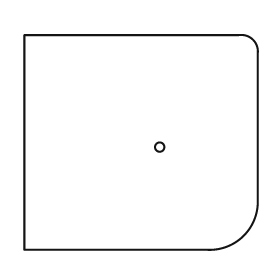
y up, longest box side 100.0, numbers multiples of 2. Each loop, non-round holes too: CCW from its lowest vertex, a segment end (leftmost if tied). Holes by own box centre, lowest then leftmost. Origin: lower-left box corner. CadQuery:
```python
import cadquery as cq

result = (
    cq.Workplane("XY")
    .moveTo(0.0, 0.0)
    .lineTo(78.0, 0.0)
    .threePointArc((94.0, 6.0), (100.0, 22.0))
    .lineTo(100.0, 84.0)
    .threePointArc((98.0, 90.0), (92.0, 92.0))
    .lineTo(0.0, 92.0)
    .close()
    .moveTo(58.0, 44.0)
    .circle(2.0)
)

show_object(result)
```